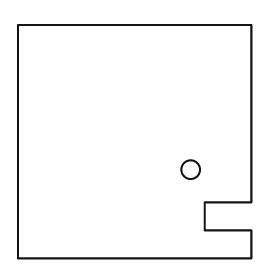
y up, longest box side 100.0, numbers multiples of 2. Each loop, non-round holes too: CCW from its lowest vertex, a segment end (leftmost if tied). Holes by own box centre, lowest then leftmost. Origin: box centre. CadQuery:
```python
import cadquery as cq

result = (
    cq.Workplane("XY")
    .moveTo(-50.0, -50.0)
    .lineTo(50.0, -50.0)
    .lineTo(50.0, -38.0)
    .lineTo(30.0, -38.0)
    .lineTo(30.0, -26.0)
    .lineTo(50.0, -26.0)
    .lineTo(50.0, 50.0)
    .lineTo(-50.0, 50.0)
    .close()
    .moveTo(24.0, -12.0)
    .circle(4.0)
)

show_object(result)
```